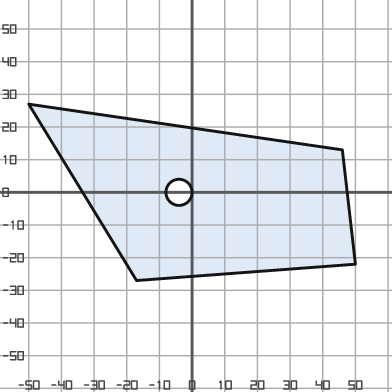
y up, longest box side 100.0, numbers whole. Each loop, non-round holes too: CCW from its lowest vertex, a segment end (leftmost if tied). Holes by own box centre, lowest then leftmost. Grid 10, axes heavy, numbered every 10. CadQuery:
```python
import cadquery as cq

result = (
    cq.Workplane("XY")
    .moveTo(-17.0, -27.0)
    .lineTo(50.0, -22.0)
    .lineTo(46.0, 13.0)
    .lineTo(-50.0, 27.0)
    .close()
    .moveTo(-4.0, 0.0)
    .circle(4.0)
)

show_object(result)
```